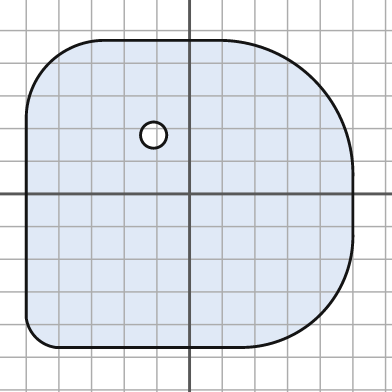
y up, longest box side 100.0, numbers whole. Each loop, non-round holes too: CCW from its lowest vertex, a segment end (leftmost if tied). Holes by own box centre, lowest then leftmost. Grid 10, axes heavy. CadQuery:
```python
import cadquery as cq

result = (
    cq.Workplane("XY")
    .moveTo(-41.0, -47.0)
    .lineTo(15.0, -47.0)
    .threePointArc((40.0, -37.0), (50.0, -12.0))
    .lineTo(50.0, 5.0)
    .threePointArc((38.0, 35.0), (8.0, 47.0))
    .lineTo(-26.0, 47.0)
    .threePointArc((-43.0, 40.0), (-50.0, 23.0))
    .lineTo(-50.0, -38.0)
    .threePointArc((-47.0, -44.0), (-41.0, -47.0))
    .close()
    .moveTo(-11.0, 18.0)
    .circle(4.0)
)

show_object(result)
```